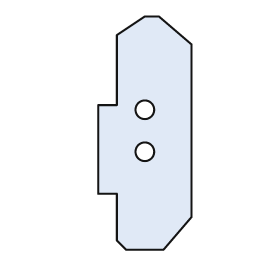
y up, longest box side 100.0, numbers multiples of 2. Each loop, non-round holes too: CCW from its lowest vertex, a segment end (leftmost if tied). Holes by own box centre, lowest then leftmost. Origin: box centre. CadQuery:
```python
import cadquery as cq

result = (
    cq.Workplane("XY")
    .moveTo(-8.0, -50.0)
    .lineTo(8.0, -50.0)
    .lineTo(20.0, -36.0)
    .lineTo(20.0, 38.0)
    .lineTo(6.0, 50.0)
    .lineTo(0.0, 50.0)
    .lineTo(-12.0, 42.0)
    .lineTo(-12.0, 12.0)
    .lineTo(-20.0, 12.0)
    .lineTo(-20.0, -26.0)
    .lineTo(-12.0, -26.0)
    .lineTo(-12.0, -46.0)
    .close()
    .moveTo(0.0, -8.0)
    .circle(4.0)
    .moveTo(0.0, 10.0)
    .circle(4.0)
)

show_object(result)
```